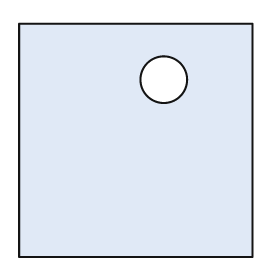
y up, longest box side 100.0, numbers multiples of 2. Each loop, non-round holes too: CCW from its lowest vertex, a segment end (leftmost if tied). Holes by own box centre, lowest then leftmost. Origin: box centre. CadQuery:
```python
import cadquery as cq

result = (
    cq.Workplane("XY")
    .moveTo(-50.0, -50.0)
    .lineTo(50.0, -50.0)
    .lineTo(50.0, 50.0)
    .lineTo(-50.0, 50.0)
    .close()
    .moveTo(12.0, 26.0)
    .circle(10.0)
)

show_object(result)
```